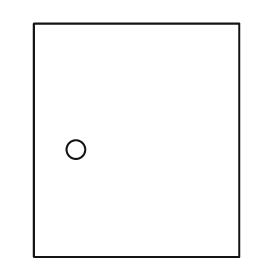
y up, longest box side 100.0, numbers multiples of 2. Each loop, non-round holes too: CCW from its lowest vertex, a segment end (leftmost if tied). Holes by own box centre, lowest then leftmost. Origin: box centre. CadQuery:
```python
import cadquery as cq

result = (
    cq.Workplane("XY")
    .moveTo(-44.0, -50.0)
    .lineTo(44.0, -50.0)
    .lineTo(44.0, 50.0)
    .lineTo(-44.0, 50.0)
    .close()
    .moveTo(-26.0, -4.0)
    .circle(4.0)
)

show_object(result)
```